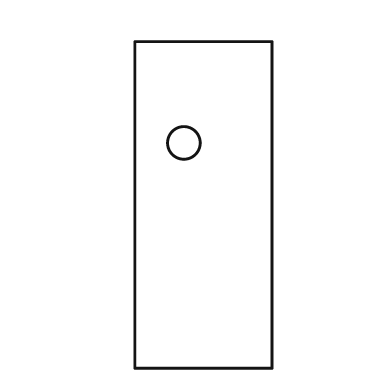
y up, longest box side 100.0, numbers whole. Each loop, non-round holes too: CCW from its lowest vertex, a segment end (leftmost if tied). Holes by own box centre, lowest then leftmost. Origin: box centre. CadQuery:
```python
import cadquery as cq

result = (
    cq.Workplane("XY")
    .moveTo(-21.0, -50.0)
    .lineTo(21.0, -50.0)
    .lineTo(21.0, 50.0)
    .lineTo(-21.0, 50.0)
    .close()
    .moveTo(-6.0, 19.0)
    .circle(5.0)
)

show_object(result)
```